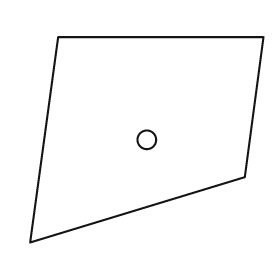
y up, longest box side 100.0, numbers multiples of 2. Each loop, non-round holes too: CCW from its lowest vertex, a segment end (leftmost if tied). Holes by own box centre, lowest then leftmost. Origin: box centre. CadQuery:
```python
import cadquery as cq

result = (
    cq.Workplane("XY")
    .moveTo(-50.0, -44.0)
    .lineTo(42.0, -16.0)
    .lineTo(50.0, 44.0)
    .lineTo(-38.0, 44.0)
    .close()
    .moveTo(0.0, 0.0)
    .circle(4.0)
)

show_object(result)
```